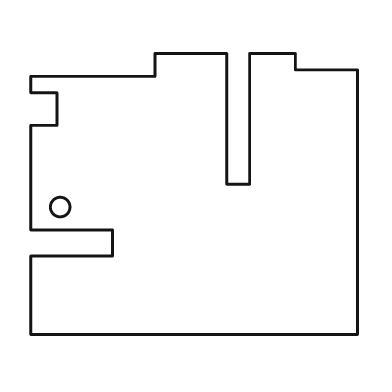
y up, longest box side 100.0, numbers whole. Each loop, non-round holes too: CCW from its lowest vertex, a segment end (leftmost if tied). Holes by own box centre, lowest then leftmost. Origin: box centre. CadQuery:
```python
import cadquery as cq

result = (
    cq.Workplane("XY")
    .moveTo(-50.0, -43.0)
    .lineTo(50.0, -43.0)
    .lineTo(50.0, 38.0)
    .lineTo(31.0, 38.0)
    .lineTo(31.0, 43.0)
    .lineTo(17.0, 43.0)
    .lineTo(17.0, 3.0)
    .lineTo(10.0, 3.0)
    .lineTo(10.0, 43.0)
    .lineTo(-12.0, 43.0)
    .lineTo(-12.0, 36.0)
    .lineTo(-50.0, 36.0)
    .lineTo(-50.0, 31.0)
    .lineTo(-42.0, 31.0)
    .lineTo(-42.0, 21.0)
    .lineTo(-50.0, 21.0)
    .lineTo(-50.0, -11.0)
    .lineTo(-25.0, -11.0)
    .lineTo(-25.0, -19.0)
    .lineTo(-50.0, -19.0)
    .close()
    .moveTo(-41.0, -4.0)
    .circle(3.0)
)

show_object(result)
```